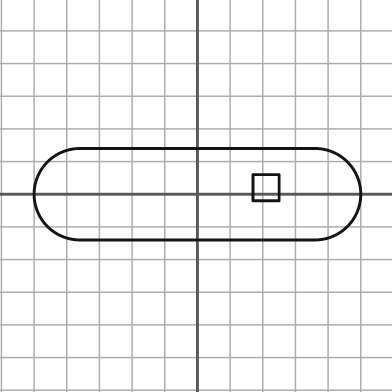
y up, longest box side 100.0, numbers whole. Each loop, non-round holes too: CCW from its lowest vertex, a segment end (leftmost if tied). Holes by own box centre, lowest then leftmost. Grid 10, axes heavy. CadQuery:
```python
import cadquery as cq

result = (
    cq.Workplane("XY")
    .moveTo(-36.0, -14.0)
    .lineTo(36.0, -14.0)
    .threePointArc((50.0, 0.0), (36.0, 14.0))
    .lineTo(-36.0, 14.0)
    .threePointArc((-50.0, 0.0), (-36.0, -14.0))
    .close()
    .moveTo(17.0, -2.0)
    .lineTo(25.0, -2.0)
    .lineTo(25.0, 6.0)
    .lineTo(17.0, 6.0)
    .close()
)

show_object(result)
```